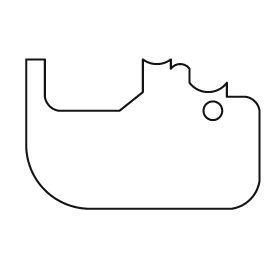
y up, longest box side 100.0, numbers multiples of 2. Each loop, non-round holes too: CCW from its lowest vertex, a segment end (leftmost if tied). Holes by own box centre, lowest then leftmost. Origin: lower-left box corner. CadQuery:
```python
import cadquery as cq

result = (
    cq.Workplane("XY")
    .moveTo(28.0, 0.0)
    .lineTo(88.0, 0.0)
    .threePointArc((96.0, 4.0), (100.0, 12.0))
    .lineTo(100.0, 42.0)
    .threePointArc((98.0, 46.0), (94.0, 48.0))
    .lineTo(86.0, 48.0)
    .lineTo(86.0, 54.0)
    .threePointArc((78.0, 50.0), (70.0, 54.0))
    .lineTo(70.0, 60.0)
    .threePointArc((66.0, 62.0), (62.0, 60.0))
    .lineTo(62.0, 64.0)
    .threePointArc((56.0, 62.0), (50.0, 64.0))
    .lineTo(50.0, 50.0)
    .lineTo(40.0, 42.0)
    .lineTo(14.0, 42.0)
    .threePointArc((10.0, 44.0), (8.0, 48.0))
    .lineTo(8.0, 64.0)
    .lineTo(0.0, 64.0)
    .lineTo(0.0, 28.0)
    .threePointArc((8.0, 8.0), (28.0, 0.0))
    .close()
    .moveTo(80.0, 42.0)
    .circle(4.0)
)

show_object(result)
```